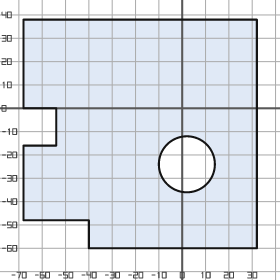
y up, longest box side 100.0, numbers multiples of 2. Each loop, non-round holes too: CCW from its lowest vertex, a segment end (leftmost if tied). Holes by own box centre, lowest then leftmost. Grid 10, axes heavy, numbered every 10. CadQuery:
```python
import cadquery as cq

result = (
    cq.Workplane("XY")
    .moveTo(-40.0, -60.0)
    .lineTo(32.0, -60.0)
    .lineTo(32.0, 38.0)
    .lineTo(-68.0, 38.0)
    .lineTo(-68.0, 0.0)
    .lineTo(-54.0, 0.0)
    .lineTo(-54.0, -16.0)
    .lineTo(-68.0, -16.0)
    .lineTo(-68.0, -48.0)
    .lineTo(-40.0, -48.0)
    .close()
    .moveTo(2.0, -24.0)
    .circle(12.0)
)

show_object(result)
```